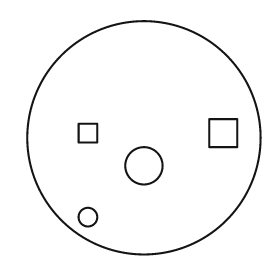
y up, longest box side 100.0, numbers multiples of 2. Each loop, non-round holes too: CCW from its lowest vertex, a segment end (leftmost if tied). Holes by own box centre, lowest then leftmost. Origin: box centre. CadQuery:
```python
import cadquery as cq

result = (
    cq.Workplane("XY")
    .moveTo(0.0, 0.0)
    .circle(50.0)
    .moveTo(-24.0, -34.0)
    .circle(4.0)
    .moveTo(0.0, -12.0)
    .circle(8.0)
    .moveTo(-28.0, -2.0)
    .lineTo(-20.0, -2.0)
    .lineTo(-20.0, 6.0)
    .lineTo(-28.0, 6.0)
    .close()
    .moveTo(28.0, -4.0)
    .lineTo(40.0, -4.0)
    .lineTo(40.0, 8.0)
    .lineTo(28.0, 8.0)
    .close()
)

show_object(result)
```